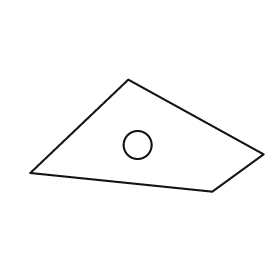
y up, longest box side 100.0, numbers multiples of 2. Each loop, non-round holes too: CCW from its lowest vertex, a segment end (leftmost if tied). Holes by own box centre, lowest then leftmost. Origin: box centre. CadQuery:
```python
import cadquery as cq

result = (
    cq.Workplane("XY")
    .moveTo(28.0, -24.0)
    .lineTo(50.0, -8.0)
    .lineTo(-8.0, 24.0)
    .lineTo(-50.0, -16.0)
    .close()
    .moveTo(-4.0, -4.0)
    .circle(6.0)
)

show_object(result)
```